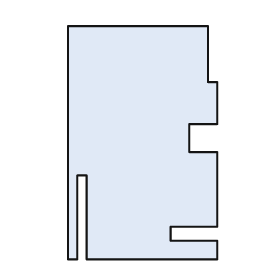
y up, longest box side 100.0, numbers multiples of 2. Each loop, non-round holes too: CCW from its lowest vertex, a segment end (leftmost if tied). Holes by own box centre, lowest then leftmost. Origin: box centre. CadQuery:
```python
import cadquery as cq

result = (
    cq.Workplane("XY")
    .moveTo(-32.0, -50.0)
    .lineTo(-28.0, -50.0)
    .lineTo(-28.0, -14.0)
    .lineTo(-24.0, -14.0)
    .lineTo(-24.0, -50.0)
    .lineTo(32.0, -50.0)
    .lineTo(32.0, -42.0)
    .lineTo(12.0, -42.0)
    .lineTo(12.0, -36.0)
    .lineTo(32.0, -36.0)
    .lineTo(32.0, -4.0)
    .lineTo(20.0, -4.0)
    .lineTo(20.0, 8.0)
    .lineTo(32.0, 8.0)
    .lineTo(32.0, 26.0)
    .lineTo(28.0, 26.0)
    .lineTo(28.0, 50.0)
    .lineTo(-32.0, 50.0)
    .close()
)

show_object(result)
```